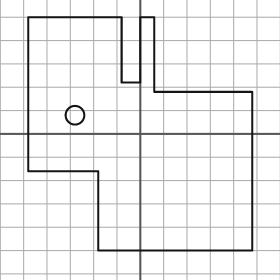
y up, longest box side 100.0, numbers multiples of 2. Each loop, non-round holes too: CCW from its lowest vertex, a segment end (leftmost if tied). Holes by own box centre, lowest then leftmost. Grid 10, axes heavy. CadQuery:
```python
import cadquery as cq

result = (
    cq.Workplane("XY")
    .moveTo(-18.0, -50.0)
    .lineTo(48.0, -50.0)
    .lineTo(48.0, 18.0)
    .lineTo(6.0, 18.0)
    .lineTo(6.0, 50.0)
    .lineTo(0.0, 50.0)
    .lineTo(0.0, 22.0)
    .lineTo(-8.0, 22.0)
    .lineTo(-8.0, 50.0)
    .lineTo(-48.0, 50.0)
    .lineTo(-48.0, -16.0)
    .lineTo(-18.0, -16.0)
    .close()
    .moveTo(-28.0, 8.0)
    .circle(4.0)
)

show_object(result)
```